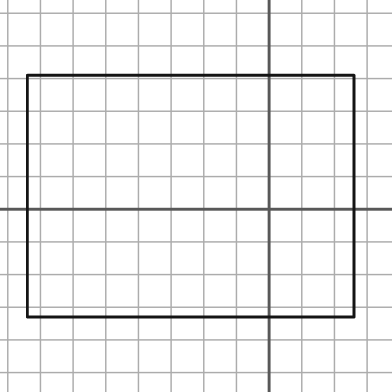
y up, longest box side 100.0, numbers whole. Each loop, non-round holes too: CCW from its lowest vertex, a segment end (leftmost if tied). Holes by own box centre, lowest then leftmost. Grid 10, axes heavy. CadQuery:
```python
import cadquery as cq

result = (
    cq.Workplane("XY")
    .moveTo(-74.0, -33.0)
    .lineTo(26.0, -33.0)
    .lineTo(26.0, 41.0)
    .lineTo(-74.0, 41.0)
    .close()
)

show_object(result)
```